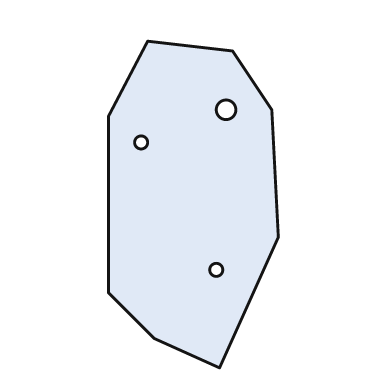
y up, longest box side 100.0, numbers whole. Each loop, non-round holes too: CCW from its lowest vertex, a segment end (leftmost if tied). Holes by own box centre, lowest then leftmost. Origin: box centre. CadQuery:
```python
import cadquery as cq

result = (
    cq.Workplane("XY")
    .moveTo(8.0, -50.0)
    .lineTo(26.0, -10.0)
    .lineTo(24.0, 29.0)
    .lineTo(12.0, 47.0)
    .lineTo(-14.0, 50.0)
    .lineTo(-26.0, 27.0)
    .lineTo(-26.0, -27.0)
    .lineTo(-12.0, -41.0)
    .close()
    .moveTo(7.0, -20.0)
    .circle(2.0)
    .moveTo(-16.0, 19.0)
    .circle(2.0)
    .moveTo(10.0, 29.0)
    .circle(3.0)
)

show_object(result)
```